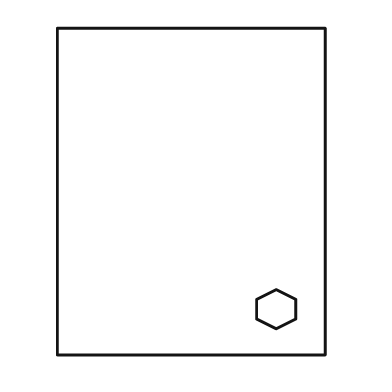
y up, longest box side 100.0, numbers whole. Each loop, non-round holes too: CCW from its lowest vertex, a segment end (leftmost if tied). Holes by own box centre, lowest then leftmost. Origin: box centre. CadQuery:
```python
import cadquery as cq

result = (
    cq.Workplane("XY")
    .moveTo(-41.0, -50.0)
    .lineTo(41.0, -50.0)
    .lineTo(41.0, 50.0)
    .lineTo(-41.0, 50.0)
    .close()
    .moveTo(26.0, -42.0)
    .lineTo(32.0, -39.0)
    .lineTo(32.0, -33.0)
    .lineTo(26.0, -30.0)
    .lineTo(20.0, -33.0)
    .lineTo(20.0, -39.0)
    .close()
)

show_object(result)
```